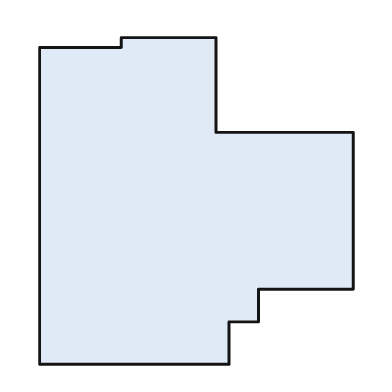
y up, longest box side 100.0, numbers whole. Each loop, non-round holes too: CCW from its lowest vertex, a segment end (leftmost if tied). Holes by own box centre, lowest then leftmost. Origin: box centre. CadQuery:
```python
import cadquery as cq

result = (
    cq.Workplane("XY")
    .moveTo(-48.0, -50.0)
    .lineTo(10.0, -50.0)
    .lineTo(10.0, -37.0)
    .lineTo(19.0, -37.0)
    .lineTo(19.0, -27.0)
    .lineTo(48.0, -27.0)
    .lineTo(48.0, 21.0)
    .lineTo(6.0, 21.0)
    .lineTo(6.0, 50.0)
    .lineTo(-23.0, 50.0)
    .lineTo(-23.0, 47.0)
    .lineTo(-48.0, 47.0)
    .close()
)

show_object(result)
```